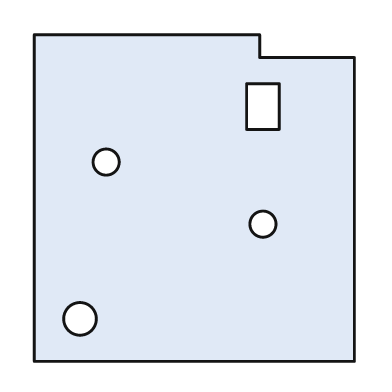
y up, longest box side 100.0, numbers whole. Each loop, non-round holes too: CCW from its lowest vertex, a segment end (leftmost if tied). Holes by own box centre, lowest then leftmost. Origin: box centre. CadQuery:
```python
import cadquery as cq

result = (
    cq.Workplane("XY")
    .moveTo(-49.0, -50.0)
    .lineTo(49.0, -50.0)
    .lineTo(49.0, 43.0)
    .lineTo(20.0, 43.0)
    .lineTo(20.0, 50.0)
    .lineTo(-49.0, 50.0)
    .close()
    .moveTo(-35.0, -37.0)
    .circle(5.0)
    .moveTo(21.0, -8.0)
    .circle(4.0)
    .moveTo(-27.0, 11.0)
    .circle(4.0)
    .moveTo(16.0, 21.0)
    .lineTo(26.0, 21.0)
    .lineTo(26.0, 35.0)
    .lineTo(16.0, 35.0)
    .close()
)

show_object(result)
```